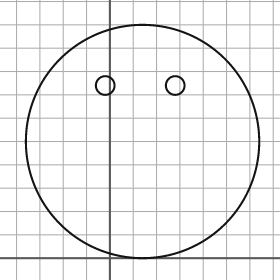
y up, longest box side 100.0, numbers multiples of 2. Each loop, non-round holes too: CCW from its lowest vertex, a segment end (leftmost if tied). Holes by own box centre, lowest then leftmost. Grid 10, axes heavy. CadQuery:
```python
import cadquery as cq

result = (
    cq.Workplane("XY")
    .moveTo(14.0, 50.0)
    .circle(50.0)
    .moveTo(-2.0, 74.0)
    .circle(4.0)
    .moveTo(28.0, 74.0)
    .circle(4.0)
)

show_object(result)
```